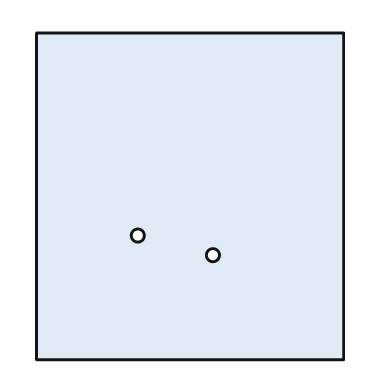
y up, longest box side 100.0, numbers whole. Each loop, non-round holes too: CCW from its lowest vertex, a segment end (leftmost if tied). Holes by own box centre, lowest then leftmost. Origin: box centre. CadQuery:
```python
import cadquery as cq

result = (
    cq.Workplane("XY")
    .moveTo(-47.0, -50.0)
    .lineTo(47.0, -50.0)
    .lineTo(47.0, 50.0)
    .lineTo(-47.0, 50.0)
    .close()
    .moveTo(7.0, -18.0)
    .circle(2.0)
    .moveTo(-16.0, -12.0)
    .circle(2.0)
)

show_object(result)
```